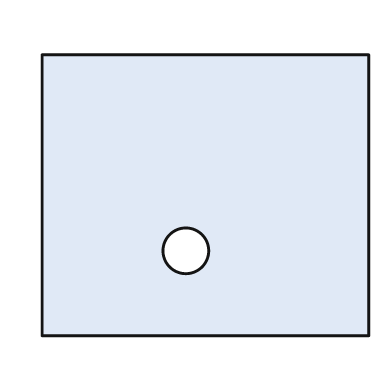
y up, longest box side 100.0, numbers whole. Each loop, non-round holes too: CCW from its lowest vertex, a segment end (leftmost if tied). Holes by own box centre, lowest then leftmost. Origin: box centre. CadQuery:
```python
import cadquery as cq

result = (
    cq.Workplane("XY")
    .moveTo(-50.0, -43.0)
    .lineTo(50.0, -43.0)
    .lineTo(50.0, 43.0)
    .lineTo(-50.0, 43.0)
    .close()
    .moveTo(-6.0, -17.0)
    .circle(7.0)
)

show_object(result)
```